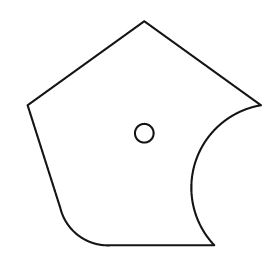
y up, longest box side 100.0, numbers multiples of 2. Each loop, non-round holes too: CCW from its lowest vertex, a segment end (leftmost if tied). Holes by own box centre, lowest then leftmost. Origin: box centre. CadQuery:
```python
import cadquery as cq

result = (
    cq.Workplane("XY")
    .moveTo(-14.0, -48.0)
    .lineTo(30.0, -48.0)
    .threePointArc((22.0, -12.0), (50.0, 12.0))
    .lineTo(0.0, 48.0)
    .lineTo(-50.0, 12.0)
    .lineTo(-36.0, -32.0)
    .threePointArc((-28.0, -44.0), (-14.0, -48.0))
    .close()
    .moveTo(0.0, 0.0)
    .circle(4.0)
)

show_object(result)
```